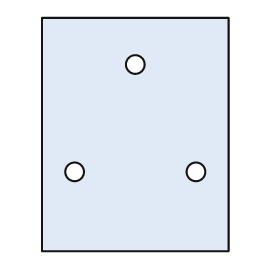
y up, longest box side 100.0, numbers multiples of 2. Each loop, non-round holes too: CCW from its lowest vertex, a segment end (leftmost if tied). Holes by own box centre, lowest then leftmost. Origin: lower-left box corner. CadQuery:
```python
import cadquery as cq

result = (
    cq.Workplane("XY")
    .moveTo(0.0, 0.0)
    .lineTo(80.0, 0.0)
    .lineTo(80.0, 100.0)
    .lineTo(0.0, 100.0)
    .close()
    .moveTo(14.0, 34.0)
    .circle(4.0)
    .moveTo(66.0, 34.0)
    .circle(4.0)
    .moveTo(40.0, 80.0)
    .circle(4.0)
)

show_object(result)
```